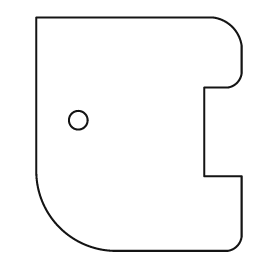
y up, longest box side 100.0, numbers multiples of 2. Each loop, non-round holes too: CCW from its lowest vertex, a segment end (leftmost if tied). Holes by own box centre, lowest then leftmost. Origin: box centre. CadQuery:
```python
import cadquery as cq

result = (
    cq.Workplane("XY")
    .moveTo(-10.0, -50.0)
    .lineTo(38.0, -50.0)
    .threePointArc((42.0, -48.0), (44.0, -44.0))
    .lineTo(44.0, -18.0)
    .lineTo(28.0, -18.0)
    .lineTo(28.0, 20.0)
    .lineTo(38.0, 20.0)
    .threePointArc((42.0, 22.0), (44.0, 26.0))
    .lineTo(44.0, 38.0)
    .threePointArc((40.0, 46.0), (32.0, 50.0))
    .lineTo(-44.0, 50.0)
    .lineTo(-44.0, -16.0)
    .threePointArc((-34.0, -40.0), (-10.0, -50.0))
    .close()
    .moveTo(-26.0, 6.0)
    .circle(4.0)
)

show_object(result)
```